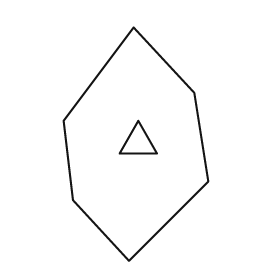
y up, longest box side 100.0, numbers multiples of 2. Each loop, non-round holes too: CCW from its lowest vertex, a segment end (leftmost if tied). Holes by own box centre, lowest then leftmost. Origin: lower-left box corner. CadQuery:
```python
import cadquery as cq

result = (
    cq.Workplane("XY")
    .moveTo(28.0, 0.0)
    .lineTo(62.0, 34.0)
    .lineTo(56.0, 72.0)
    .lineTo(30.0, 100.0)
    .lineTo(0.0, 60.0)
    .lineTo(4.0, 26.0)
    .close()
    .moveTo(24.0, 46.0)
    .lineTo(40.0, 46.0)
    .lineTo(32.0, 60.0)
    .close()
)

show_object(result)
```